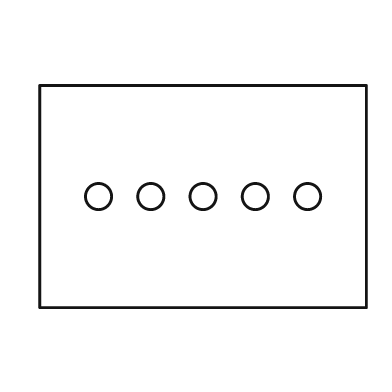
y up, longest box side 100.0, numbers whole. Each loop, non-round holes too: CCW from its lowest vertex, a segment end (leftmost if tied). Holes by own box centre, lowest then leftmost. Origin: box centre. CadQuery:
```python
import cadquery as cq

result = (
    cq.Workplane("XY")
    .moveTo(-50.0, -34.0)
    .lineTo(50.0, -34.0)
    .lineTo(50.0, 34.0)
    .lineTo(-50.0, 34.0)
    .close()
    .moveTo(-32.0, 0.0)
    .circle(4.0)
    .moveTo(-16.0, 0.0)
    .circle(4.0)
    .moveTo(0.0, 0.0)
    .circle(4.0)
    .moveTo(16.0, 0.0)
    .circle(4.0)
    .moveTo(32.0, 0.0)
    .circle(4.0)
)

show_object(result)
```